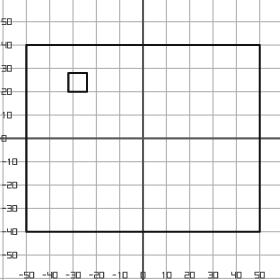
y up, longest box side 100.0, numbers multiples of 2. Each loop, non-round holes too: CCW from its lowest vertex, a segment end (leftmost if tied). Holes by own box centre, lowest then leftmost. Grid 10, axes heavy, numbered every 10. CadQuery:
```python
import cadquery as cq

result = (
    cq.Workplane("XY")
    .moveTo(-50.0, -40.0)
    .lineTo(50.0, -40.0)
    .lineTo(50.0, 40.0)
    .lineTo(-50.0, 40.0)
    .close()
    .moveTo(-32.0, 20.0)
    .lineTo(-24.0, 20.0)
    .lineTo(-24.0, 28.0)
    .lineTo(-32.0, 28.0)
    .close()
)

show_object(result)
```